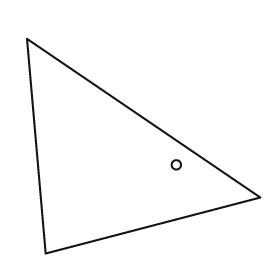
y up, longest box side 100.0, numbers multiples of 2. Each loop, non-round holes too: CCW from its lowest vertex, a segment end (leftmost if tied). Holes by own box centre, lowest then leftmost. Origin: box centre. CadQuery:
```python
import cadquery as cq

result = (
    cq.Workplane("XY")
    .moveTo(-42.0, -46.0)
    .lineTo(50.0, -22.0)
    .lineTo(-50.0, 46.0)
    .close()
    .moveTo(14.0, -8.0)
    .circle(2.0)
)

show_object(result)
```